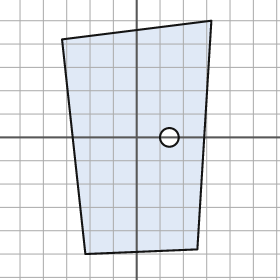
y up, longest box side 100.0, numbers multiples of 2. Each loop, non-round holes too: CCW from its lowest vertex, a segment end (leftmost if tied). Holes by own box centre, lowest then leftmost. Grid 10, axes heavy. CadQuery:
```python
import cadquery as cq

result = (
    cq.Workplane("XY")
    .moveTo(-22.0, -50.0)
    .lineTo(26.0, -48.0)
    .lineTo(32.0, 50.0)
    .lineTo(-32.0, 42.0)
    .close()
    .moveTo(14.0, 0.0)
    .circle(4.0)
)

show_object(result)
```